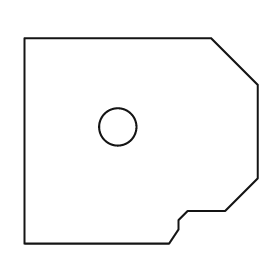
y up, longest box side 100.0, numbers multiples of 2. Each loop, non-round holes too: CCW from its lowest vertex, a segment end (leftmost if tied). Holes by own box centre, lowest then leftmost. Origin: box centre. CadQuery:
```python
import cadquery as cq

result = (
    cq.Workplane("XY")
    .moveTo(-50.0, -44.0)
    .lineTo(12.0, -44.0)
    .lineTo(16.0, -38.0)
    .lineTo(16.0, -34.0)
    .lineTo(20.0, -30.0)
    .lineTo(36.0, -30.0)
    .lineTo(50.0, -16.0)
    .lineTo(50.0, 24.0)
    .lineTo(30.0, 44.0)
    .lineTo(-50.0, 44.0)
    .close()
    .moveTo(-10.0, 6.0)
    .circle(8.0)
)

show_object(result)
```